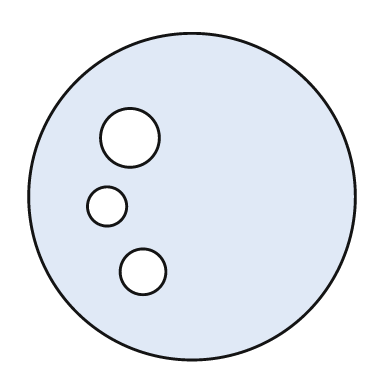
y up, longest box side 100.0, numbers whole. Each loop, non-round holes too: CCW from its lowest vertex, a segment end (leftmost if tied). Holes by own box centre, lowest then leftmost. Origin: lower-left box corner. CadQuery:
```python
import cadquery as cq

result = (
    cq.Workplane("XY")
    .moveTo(50.0, 50.0)
    .circle(50.0)
    .moveTo(35.0, 27.0)
    .circle(7.0)
    .moveTo(24.0, 47.0)
    .circle(6.0)
    .moveTo(31.0, 68.0)
    .circle(9.0)
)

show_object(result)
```